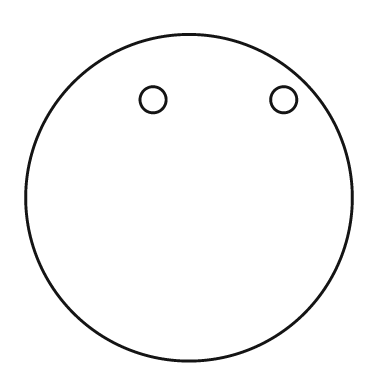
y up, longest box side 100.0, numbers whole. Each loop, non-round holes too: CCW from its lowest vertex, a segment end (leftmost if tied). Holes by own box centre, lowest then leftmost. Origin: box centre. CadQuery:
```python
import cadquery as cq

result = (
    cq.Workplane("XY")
    .moveTo(0.0, 0.0)
    .circle(50.0)
    .moveTo(-11.0, 30.0)
    .circle(4.0)
    .moveTo(29.0, 30.0)
    .circle(4.0)
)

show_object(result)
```